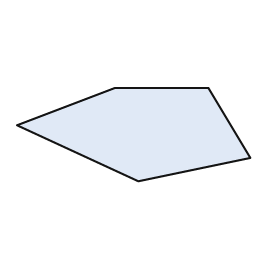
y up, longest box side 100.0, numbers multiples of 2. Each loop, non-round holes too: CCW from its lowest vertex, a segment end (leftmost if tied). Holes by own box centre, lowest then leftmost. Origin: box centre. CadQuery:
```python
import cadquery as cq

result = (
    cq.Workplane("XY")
    .moveTo(2.0, -20.0)
    .lineTo(50.0, -10.0)
    .lineTo(32.0, 20.0)
    .lineTo(-8.0, 20.0)
    .lineTo(-50.0, 4.0)
    .close()
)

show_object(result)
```